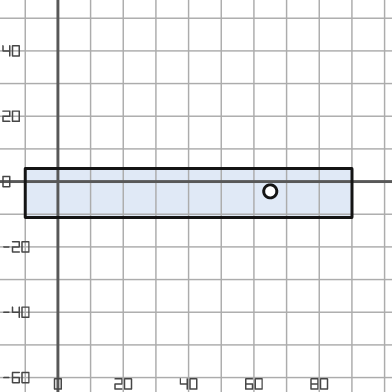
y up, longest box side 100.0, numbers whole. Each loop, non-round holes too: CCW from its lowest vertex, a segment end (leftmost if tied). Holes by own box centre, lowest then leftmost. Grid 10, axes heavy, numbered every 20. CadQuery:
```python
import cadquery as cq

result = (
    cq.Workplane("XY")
    .moveTo(-10.0, -11.0)
    .lineTo(90.0, -11.0)
    .lineTo(90.0, 4.0)
    .lineTo(-10.0, 4.0)
    .close()
    .moveTo(65.0, -3.0)
    .circle(2.0)
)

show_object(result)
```